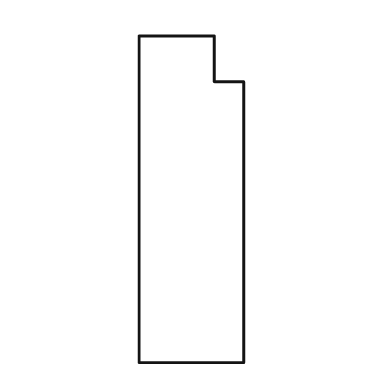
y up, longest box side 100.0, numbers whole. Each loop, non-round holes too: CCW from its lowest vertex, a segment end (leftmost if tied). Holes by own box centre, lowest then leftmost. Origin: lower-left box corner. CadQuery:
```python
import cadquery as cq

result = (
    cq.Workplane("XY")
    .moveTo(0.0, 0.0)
    .lineTo(32.0, 0.0)
    .lineTo(32.0, 86.0)
    .lineTo(23.0, 86.0)
    .lineTo(23.0, 100.0)
    .lineTo(0.0, 100.0)
    .close()
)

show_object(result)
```